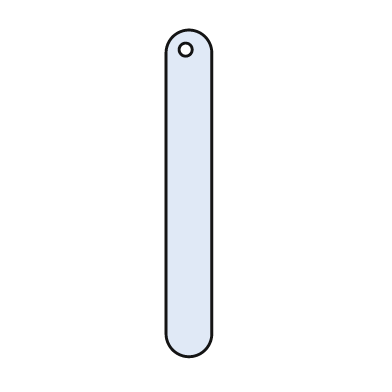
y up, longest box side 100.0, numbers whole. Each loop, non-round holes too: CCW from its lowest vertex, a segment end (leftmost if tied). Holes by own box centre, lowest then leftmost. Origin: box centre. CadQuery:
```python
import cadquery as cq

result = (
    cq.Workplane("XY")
    .moveTo(-7.0, -43.0)
    .threePointArc((0.0, -50.0), (7.0, -43.0))
    .lineTo(7.0, 43.0)
    .threePointArc((0.0, 50.0), (-7.0, 43.0))
    .close()
    .moveTo(-1.0, 44.0)
    .circle(2.0)
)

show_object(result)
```